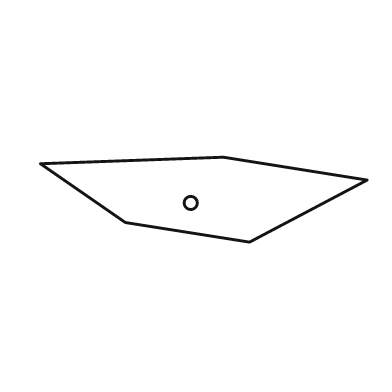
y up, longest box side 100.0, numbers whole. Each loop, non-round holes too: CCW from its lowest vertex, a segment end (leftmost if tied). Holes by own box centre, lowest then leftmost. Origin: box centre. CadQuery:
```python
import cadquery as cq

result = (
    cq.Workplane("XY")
    .moveTo(14.0, -13.0)
    .lineTo(50.0, 6.0)
    .lineTo(6.0, 13.0)
    .lineTo(-50.0, 11.0)
    .lineTo(-24.0, -7.0)
    .close()
    .moveTo(-4.0, -1.0)
    .circle(2.0)
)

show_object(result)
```